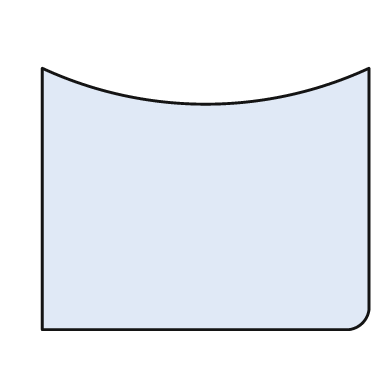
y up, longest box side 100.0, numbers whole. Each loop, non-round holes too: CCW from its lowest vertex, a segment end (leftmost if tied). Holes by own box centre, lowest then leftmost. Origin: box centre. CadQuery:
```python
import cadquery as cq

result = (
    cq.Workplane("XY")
    .moveTo(-50.0, -40.0)
    .lineTo(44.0, -40.0)
    .threePointArc((48.0, -38.0), (50.0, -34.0))
    .lineTo(50.0, 40.0)
    .threePointArc((0.0, 29.0), (-50.0, 40.0))
    .close()
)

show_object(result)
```